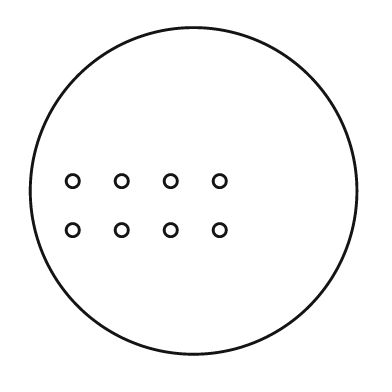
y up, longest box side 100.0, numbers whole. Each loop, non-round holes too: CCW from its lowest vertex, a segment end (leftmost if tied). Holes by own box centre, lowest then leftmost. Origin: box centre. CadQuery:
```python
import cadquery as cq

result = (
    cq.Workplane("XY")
    .moveTo(0.0, 0.0)
    .circle(50.0)
    .moveTo(-37.0, -12.0)
    .circle(2.0)
    .moveTo(-22.0, -12.0)
    .circle(2.0)
    .moveTo(-7.0, -12.0)
    .circle(2.0)
    .moveTo(8.0, -12.0)
    .circle(2.0)
    .moveTo(-37.0, 3.0)
    .circle(2.0)
    .moveTo(-22.0, 3.0)
    .circle(2.0)
    .moveTo(-7.0, 3.0)
    .circle(2.0)
    .moveTo(8.0, 3.0)
    .circle(2.0)
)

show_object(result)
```